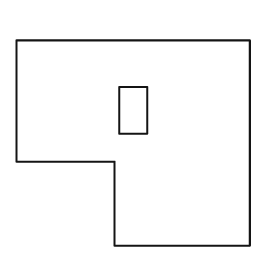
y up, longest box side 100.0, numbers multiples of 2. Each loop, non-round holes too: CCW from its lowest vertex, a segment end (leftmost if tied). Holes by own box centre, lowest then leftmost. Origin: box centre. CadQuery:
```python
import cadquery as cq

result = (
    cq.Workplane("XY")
    .moveTo(-8.0, -44.0)
    .lineTo(50.0, -44.0)
    .lineTo(50.0, 44.0)
    .lineTo(-50.0, 44.0)
    .lineTo(-50.0, -8.0)
    .lineTo(-8.0, -8.0)
    .close()
    .moveTo(-6.0, 4.0)
    .lineTo(6.0, 4.0)
    .lineTo(6.0, 24.0)
    .lineTo(-6.0, 24.0)
    .close()
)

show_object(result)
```